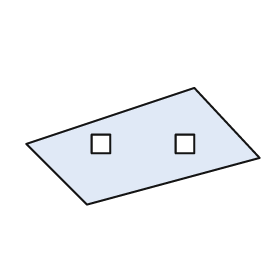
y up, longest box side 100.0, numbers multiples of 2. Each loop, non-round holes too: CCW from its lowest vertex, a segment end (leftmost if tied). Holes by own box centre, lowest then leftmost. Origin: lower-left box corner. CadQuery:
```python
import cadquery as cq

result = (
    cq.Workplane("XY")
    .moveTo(26.0, 0.0)
    .lineTo(100.0, 20.0)
    .lineTo(72.0, 50.0)
    .lineTo(0.0, 26.0)
    .close()
    .moveTo(28.0, 22.0)
    .lineTo(36.0, 22.0)
    .lineTo(36.0, 30.0)
    .lineTo(28.0, 30.0)
    .close()
    .moveTo(64.0, 22.0)
    .lineTo(72.0, 22.0)
    .lineTo(72.0, 30.0)
    .lineTo(64.0, 30.0)
    .close()
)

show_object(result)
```